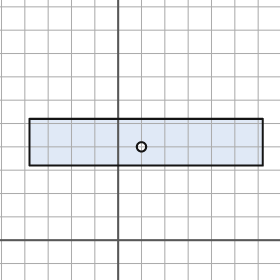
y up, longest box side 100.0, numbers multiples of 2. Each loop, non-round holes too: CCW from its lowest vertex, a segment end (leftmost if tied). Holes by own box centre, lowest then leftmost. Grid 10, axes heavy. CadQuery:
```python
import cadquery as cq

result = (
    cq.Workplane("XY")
    .moveTo(-38.0, 32.0)
    .lineTo(62.0, 32.0)
    .lineTo(62.0, 52.0)
    .lineTo(-38.0, 52.0)
    .close()
    .moveTo(10.0, 40.0)
    .circle(2.0)
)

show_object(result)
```